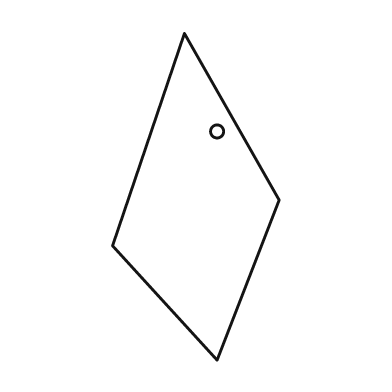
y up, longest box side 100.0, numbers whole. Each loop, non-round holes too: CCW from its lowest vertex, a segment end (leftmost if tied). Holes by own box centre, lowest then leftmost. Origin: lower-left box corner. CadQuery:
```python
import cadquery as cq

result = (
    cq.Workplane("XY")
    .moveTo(32.0, 0.0)
    .lineTo(51.0, 49.0)
    .lineTo(22.0, 100.0)
    .lineTo(0.0, 35.0)
    .close()
    .moveTo(32.0, 70.0)
    .circle(2.0)
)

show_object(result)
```